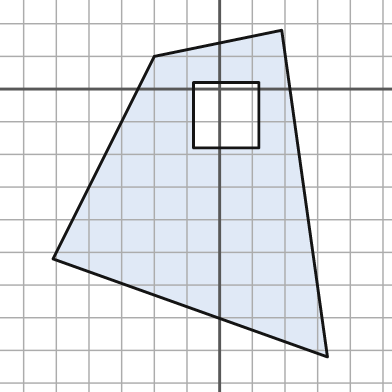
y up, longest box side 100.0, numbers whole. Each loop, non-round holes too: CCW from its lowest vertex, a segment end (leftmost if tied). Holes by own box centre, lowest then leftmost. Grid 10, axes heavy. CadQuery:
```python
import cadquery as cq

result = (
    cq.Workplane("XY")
    .moveTo(33.0, -82.0)
    .lineTo(19.0, 18.0)
    .lineTo(-20.0, 10.0)
    .lineTo(-51.0, -52.0)
    .close()
    .moveTo(-8.0, -18.0)
    .lineTo(12.0, -18.0)
    .lineTo(12.0, 2.0)
    .lineTo(-8.0, 2.0)
    .close()
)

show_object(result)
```